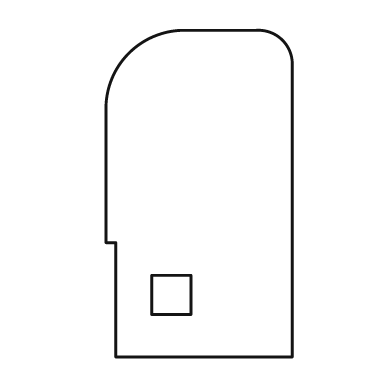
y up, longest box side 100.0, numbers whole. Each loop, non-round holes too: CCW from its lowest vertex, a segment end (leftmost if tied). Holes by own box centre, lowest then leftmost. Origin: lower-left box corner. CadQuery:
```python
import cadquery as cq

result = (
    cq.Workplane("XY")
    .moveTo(3.0, 0.0)
    .lineTo(57.0, 0.0)
    .lineTo(57.0, 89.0)
    .threePointArc((54.0, 97.0), (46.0, 100.0))
    .lineTo(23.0, 100.0)
    .threePointArc((7.0, 93.0), (0.0, 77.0))
    .lineTo(0.0, 35.0)
    .lineTo(3.0, 35.0)
    .close()
    .moveTo(14.0, 13.0)
    .lineTo(26.0, 13.0)
    .lineTo(26.0, 25.0)
    .lineTo(14.0, 25.0)
    .close()
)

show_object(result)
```